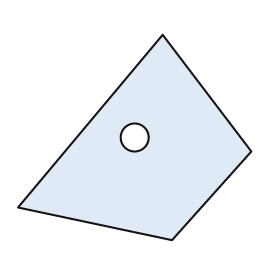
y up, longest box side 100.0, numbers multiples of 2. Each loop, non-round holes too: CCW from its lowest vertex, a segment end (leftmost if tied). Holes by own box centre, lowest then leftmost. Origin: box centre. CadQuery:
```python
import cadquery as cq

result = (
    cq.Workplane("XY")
    .moveTo(16.0, -44.0)
    .lineTo(50.0, -6.0)
    .lineTo(12.0, 44.0)
    .lineTo(-50.0, -30.0)
    .close()
    .moveTo(0.0, 0.0)
    .circle(6.0)
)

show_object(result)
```